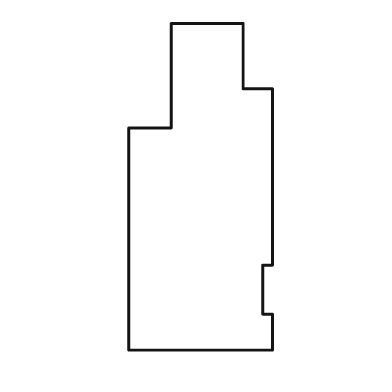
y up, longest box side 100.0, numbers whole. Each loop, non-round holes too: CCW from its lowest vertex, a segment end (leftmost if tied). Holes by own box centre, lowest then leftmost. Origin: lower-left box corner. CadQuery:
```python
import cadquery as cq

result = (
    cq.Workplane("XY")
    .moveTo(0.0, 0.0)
    .lineTo(44.0, 0.0)
    .lineTo(44.0, 11.0)
    .lineTo(41.0, 11.0)
    .lineTo(41.0, 26.0)
    .lineTo(44.0, 26.0)
    .lineTo(44.0, 80.0)
    .lineTo(35.0, 80.0)
    .lineTo(35.0, 100.0)
    .lineTo(13.0, 100.0)
    .lineTo(13.0, 68.0)
    .lineTo(0.0, 68.0)
    .close()
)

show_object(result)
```